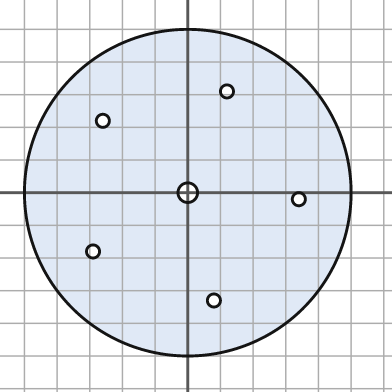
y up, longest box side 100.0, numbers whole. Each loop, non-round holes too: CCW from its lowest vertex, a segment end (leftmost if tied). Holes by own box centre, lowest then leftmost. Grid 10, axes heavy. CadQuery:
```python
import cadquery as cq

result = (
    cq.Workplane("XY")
    .moveTo(0.0, 0.0)
    .circle(50.0)
    .moveTo(8.0, -33.0)
    .circle(2.0)
    .moveTo(-29.0, -18.0)
    .circle(2.0)
    .moveTo(34.0, -2.0)
    .circle(2.0)
    .moveTo(0.0, 0.0)
    .circle(3.0)
    .moveTo(-26.0, 22.0)
    .circle(2.0)
    .moveTo(12.0, 31.0)
    .circle(2.0)
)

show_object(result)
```